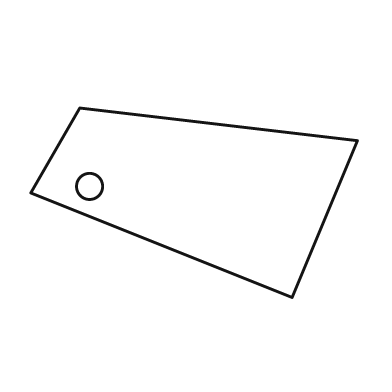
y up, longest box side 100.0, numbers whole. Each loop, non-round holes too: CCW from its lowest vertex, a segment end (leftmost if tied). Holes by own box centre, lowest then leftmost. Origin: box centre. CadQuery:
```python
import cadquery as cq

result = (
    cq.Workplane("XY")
    .moveTo(30.0, -29.0)
    .lineTo(50.0, 19.0)
    .lineTo(-35.0, 29.0)
    .lineTo(-50.0, 3.0)
    .close()
    .moveTo(-32.0, 5.0)
    .circle(4.0)
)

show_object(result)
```